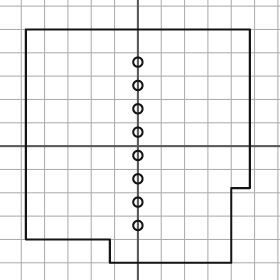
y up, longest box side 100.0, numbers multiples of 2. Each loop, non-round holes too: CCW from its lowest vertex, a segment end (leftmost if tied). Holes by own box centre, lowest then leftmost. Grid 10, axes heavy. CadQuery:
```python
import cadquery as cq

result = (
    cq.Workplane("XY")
    .moveTo(-12.0, -50.0)
    .lineTo(40.0, -50.0)
    .lineTo(40.0, -18.0)
    .lineTo(48.0, -18.0)
    .lineTo(48.0, 50.0)
    .lineTo(-48.0, 50.0)
    .lineTo(-48.0, -40.0)
    .lineTo(-12.0, -40.0)
    .close()
    .moveTo(0.0, -34.0)
    .circle(2.0)
    .moveTo(0.0, -24.0)
    .circle(2.0)
    .moveTo(0.0, -14.0)
    .circle(2.0)
    .moveTo(0.0, -4.0)
    .circle(2.0)
    .moveTo(0.0, 6.0)
    .circle(2.0)
    .moveTo(0.0, 16.0)
    .circle(2.0)
    .moveTo(0.0, 26.0)
    .circle(2.0)
    .moveTo(0.0, 36.0)
    .circle(2.0)
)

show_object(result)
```